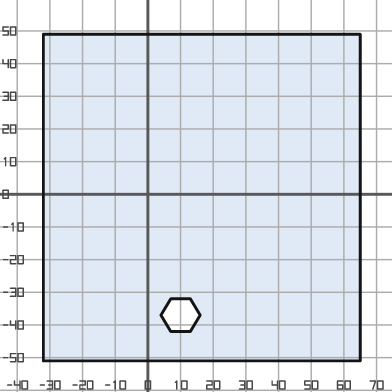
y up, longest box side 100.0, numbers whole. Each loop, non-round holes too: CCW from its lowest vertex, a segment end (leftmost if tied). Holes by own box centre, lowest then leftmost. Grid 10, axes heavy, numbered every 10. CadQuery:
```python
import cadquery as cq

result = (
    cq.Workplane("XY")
    .moveTo(-32.0, -51.0)
    .lineTo(65.0, -51.0)
    .lineTo(65.0, 49.0)
    .lineTo(-32.0, 49.0)
    .close()
    .moveTo(7.0, -42.0)
    .lineTo(13.0, -42.0)
    .lineTo(16.0, -37.0)
    .lineTo(13.0, -32.0)
    .lineTo(7.0, -32.0)
    .lineTo(4.0, -37.0)
    .close()
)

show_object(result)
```